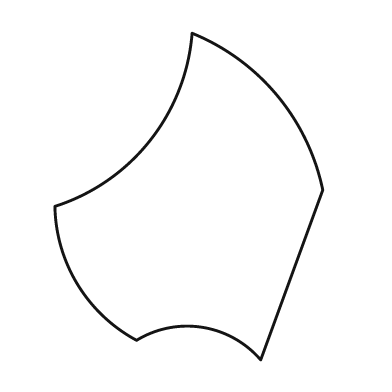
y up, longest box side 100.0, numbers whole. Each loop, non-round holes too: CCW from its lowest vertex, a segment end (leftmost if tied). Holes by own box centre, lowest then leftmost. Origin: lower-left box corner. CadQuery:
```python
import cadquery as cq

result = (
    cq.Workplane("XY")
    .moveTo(63.0, 0.0)
    .lineTo(82.0, 52.0)
    .threePointArc((68.0, 81.0), (42.0, 100.0))
    .threePointArc((29.0, 67.0), (0.0, 47.0))
    .threePointArc((7.0, 23.0), (25.0, 6.0))
    .threePointArc((45.0, 10.0), (63.0, 0.0))
    .close()
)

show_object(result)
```